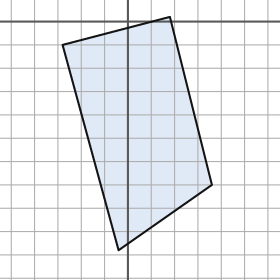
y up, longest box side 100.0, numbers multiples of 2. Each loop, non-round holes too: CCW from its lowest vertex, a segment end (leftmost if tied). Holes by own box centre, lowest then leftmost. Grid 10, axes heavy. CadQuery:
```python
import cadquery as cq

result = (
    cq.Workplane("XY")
    .moveTo(-4.0, -98.0)
    .lineTo(36.0, -70.0)
    .lineTo(18.0, 2.0)
    .lineTo(-28.0, -10.0)
    .close()
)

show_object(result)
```